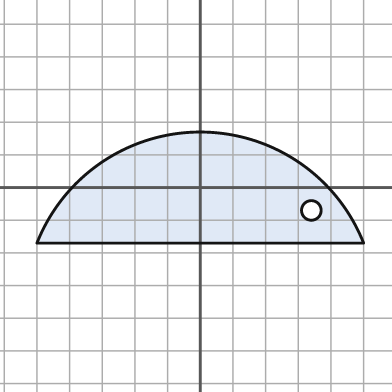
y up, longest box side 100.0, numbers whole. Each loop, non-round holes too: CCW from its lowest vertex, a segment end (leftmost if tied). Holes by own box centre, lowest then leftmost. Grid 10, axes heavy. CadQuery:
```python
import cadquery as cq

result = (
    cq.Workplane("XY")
    .moveTo(-50.0, -17.0)
    .lineTo(50.0, -17.0)
    .threePointArc((0.0, 17.0), (-50.0, -17.0))
    .close()
    .moveTo(34.0, -7.0)
    .circle(3.0)
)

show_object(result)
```